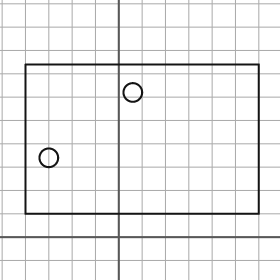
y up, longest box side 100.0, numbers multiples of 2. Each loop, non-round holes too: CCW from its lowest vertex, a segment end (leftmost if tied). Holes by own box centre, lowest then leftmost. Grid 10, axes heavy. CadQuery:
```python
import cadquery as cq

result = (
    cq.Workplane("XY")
    .moveTo(-40.0, 10.0)
    .lineTo(60.0, 10.0)
    .lineTo(60.0, 74.0)
    .lineTo(-40.0, 74.0)
    .close()
    .moveTo(-30.0, 34.0)
    .circle(4.0)
    .moveTo(6.0, 62.0)
    .circle(4.0)
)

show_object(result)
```